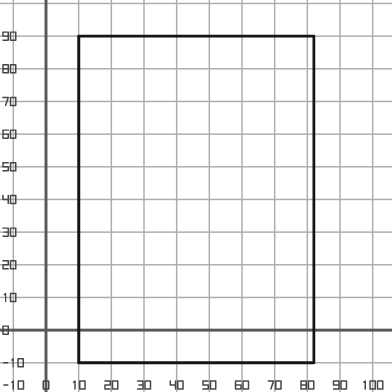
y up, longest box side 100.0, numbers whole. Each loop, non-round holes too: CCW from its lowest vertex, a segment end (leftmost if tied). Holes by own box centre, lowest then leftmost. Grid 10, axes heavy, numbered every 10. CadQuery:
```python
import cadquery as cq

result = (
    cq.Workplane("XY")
    .moveTo(10.0, -10.0)
    .lineTo(82.0, -10.0)
    .lineTo(82.0, 90.0)
    .lineTo(10.0, 90.0)
    .close()
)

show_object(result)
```